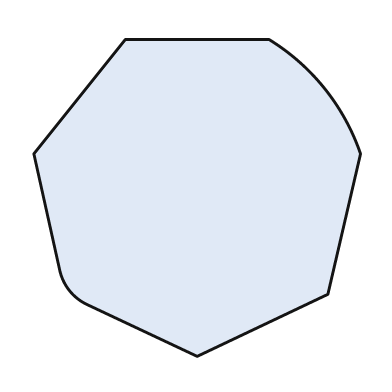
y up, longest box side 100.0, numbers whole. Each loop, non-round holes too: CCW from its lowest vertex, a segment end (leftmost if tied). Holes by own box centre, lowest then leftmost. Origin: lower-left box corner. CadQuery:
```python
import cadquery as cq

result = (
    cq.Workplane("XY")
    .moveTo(50.0, 0.0)
    .lineTo(90.0, 19.0)
    .lineTo(100.0, 62.0)
    .threePointArc((89.0, 82.0), (72.0, 97.0))
    .lineTo(28.0, 97.0)
    .lineTo(0.0, 62.0)
    .lineTo(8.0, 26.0)
    .threePointArc((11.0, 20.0), (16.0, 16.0))
    .close()
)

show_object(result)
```